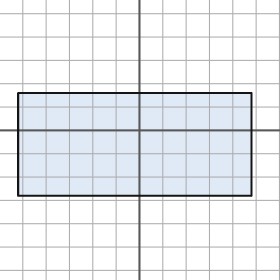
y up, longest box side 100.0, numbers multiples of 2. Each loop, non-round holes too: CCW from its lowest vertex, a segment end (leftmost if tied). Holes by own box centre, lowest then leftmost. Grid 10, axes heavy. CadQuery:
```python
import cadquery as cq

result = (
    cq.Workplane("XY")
    .moveTo(-52.0, -28.0)
    .lineTo(48.0, -28.0)
    .lineTo(48.0, 16.0)
    .lineTo(-52.0, 16.0)
    .close()
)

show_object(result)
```